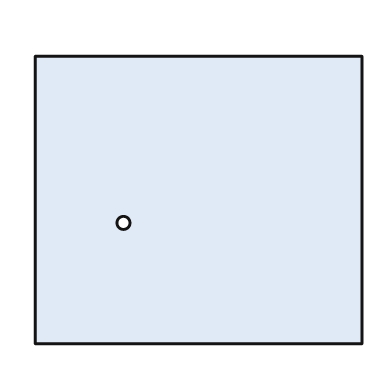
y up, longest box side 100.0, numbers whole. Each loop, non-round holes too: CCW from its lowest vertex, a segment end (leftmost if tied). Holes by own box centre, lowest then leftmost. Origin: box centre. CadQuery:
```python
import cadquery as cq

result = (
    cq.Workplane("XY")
    .moveTo(-50.0, -44.0)
    .lineTo(50.0, -44.0)
    .lineTo(50.0, 44.0)
    .lineTo(-50.0, 44.0)
    .close()
    .moveTo(-23.0, -7.0)
    .circle(2.0)
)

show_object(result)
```